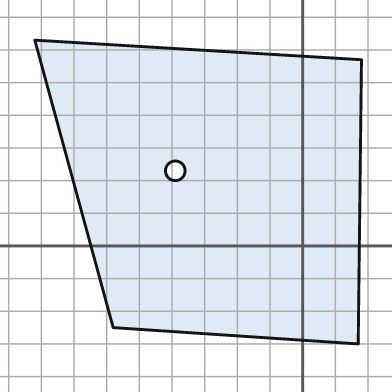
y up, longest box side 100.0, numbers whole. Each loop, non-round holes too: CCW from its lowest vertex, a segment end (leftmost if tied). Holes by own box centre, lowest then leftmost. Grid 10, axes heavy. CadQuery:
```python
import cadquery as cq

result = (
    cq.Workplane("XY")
    .moveTo(17.0, -30.0)
    .lineTo(18.0, 57.0)
    .lineTo(-82.0, 63.0)
    .lineTo(-58.0, -25.0)
    .close()
    .moveTo(-39.0, 23.0)
    .circle(3.0)
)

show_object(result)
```